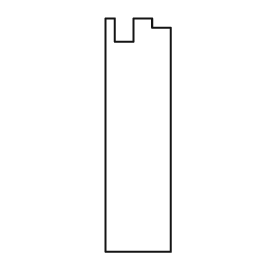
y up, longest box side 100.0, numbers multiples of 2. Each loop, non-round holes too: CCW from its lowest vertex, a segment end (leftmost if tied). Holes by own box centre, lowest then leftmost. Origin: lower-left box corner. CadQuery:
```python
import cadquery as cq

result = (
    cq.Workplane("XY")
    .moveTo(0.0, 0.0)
    .lineTo(28.0, 0.0)
    .lineTo(28.0, 96.0)
    .lineTo(20.0, 96.0)
    .lineTo(20.0, 100.0)
    .lineTo(12.0, 100.0)
    .lineTo(12.0, 90.0)
    .lineTo(4.0, 90.0)
    .lineTo(4.0, 100.0)
    .lineTo(0.0, 100.0)
    .close()
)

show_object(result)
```